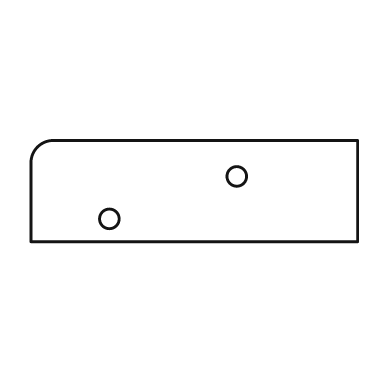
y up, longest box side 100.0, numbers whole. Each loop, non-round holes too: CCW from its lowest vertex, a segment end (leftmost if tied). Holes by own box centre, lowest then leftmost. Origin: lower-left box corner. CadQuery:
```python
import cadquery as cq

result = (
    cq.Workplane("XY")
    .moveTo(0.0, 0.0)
    .lineTo(100.0, 0.0)
    .lineTo(100.0, 31.0)
    .lineTo(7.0, 31.0)
    .threePointArc((2.0, 29.0), (0.0, 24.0))
    .close()
    .moveTo(24.0, 7.0)
    .circle(3.0)
    .moveTo(63.0, 20.0)
    .circle(3.0)
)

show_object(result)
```